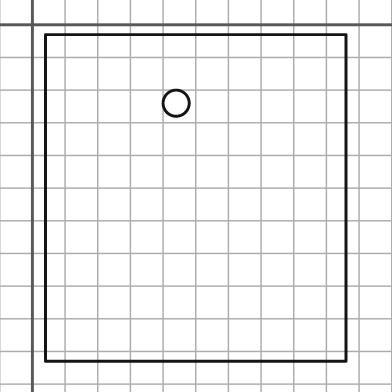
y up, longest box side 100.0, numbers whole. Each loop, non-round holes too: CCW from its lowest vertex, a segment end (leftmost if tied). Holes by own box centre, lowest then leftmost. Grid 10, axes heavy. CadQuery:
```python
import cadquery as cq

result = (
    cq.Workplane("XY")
    .moveTo(4.0, -103.0)
    .lineTo(96.0, -103.0)
    .lineTo(96.0, -3.0)
    .lineTo(4.0, -3.0)
    .close()
    .moveTo(44.0, -24.0)
    .circle(4.0)
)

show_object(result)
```